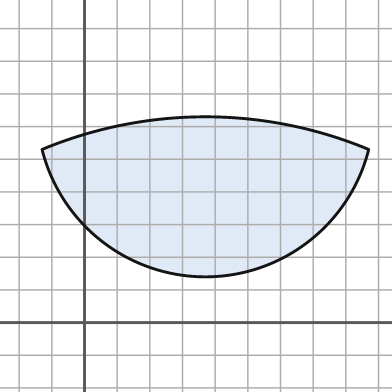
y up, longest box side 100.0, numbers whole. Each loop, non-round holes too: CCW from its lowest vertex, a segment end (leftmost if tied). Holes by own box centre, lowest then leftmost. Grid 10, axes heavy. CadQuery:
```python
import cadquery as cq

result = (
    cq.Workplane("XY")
    .moveTo(-13.0, 53.0)
    .threePointArc((37.0, 14.0), (87.0, 53.0))
    .threePointArc((37.0, 63.0), (-13.0, 53.0))
    .close()
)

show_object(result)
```